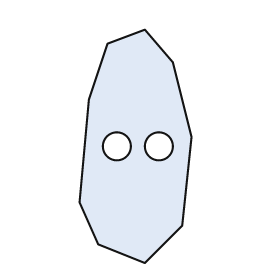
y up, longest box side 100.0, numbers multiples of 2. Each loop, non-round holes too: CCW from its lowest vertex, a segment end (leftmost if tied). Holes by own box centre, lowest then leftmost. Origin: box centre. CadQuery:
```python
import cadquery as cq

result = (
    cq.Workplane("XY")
    .moveTo(4.0, -50.0)
    .lineTo(20.0, -34.0)
    .lineTo(24.0, 4.0)
    .lineTo(16.0, 36.0)
    .lineTo(4.0, 50.0)
    .lineTo(-12.0, 44.0)
    .lineTo(-20.0, 20.0)
    .lineTo(-24.0, -24.0)
    .lineTo(-16.0, -42.0)
    .close()
    .moveTo(-8.0, 0.0)
    .circle(6.0)
    .moveTo(10.0, 0.0)
    .circle(6.0)
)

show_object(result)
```